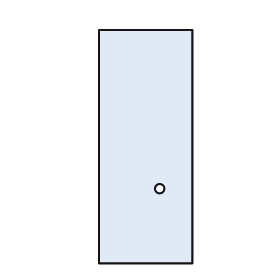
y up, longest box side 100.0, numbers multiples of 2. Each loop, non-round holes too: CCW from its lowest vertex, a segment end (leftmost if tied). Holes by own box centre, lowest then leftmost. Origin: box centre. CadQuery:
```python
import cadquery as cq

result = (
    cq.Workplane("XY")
    .moveTo(-20.0, -50.0)
    .lineTo(20.0, -50.0)
    .lineTo(20.0, 50.0)
    .lineTo(-20.0, 50.0)
    .close()
    .moveTo(6.0, -18.0)
    .circle(2.0)
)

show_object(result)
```